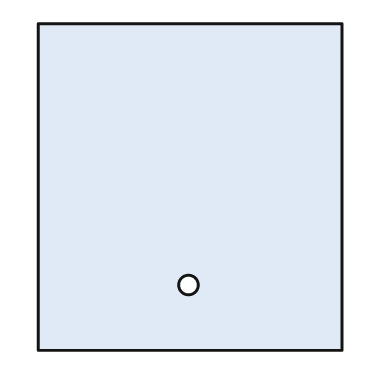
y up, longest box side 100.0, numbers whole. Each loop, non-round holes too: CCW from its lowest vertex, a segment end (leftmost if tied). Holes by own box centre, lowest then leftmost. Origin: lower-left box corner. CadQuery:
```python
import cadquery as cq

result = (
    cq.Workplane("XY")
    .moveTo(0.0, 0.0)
    .lineTo(93.0, 0.0)
    .lineTo(93.0, 100.0)
    .lineTo(0.0, 100.0)
    .close()
    .moveTo(46.0, 20.0)
    .circle(3.0)
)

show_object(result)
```